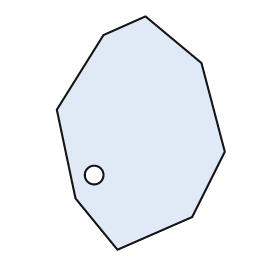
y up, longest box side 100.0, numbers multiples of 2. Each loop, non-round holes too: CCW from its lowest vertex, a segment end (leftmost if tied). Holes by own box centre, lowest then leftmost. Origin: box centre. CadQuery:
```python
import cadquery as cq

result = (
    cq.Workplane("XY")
    .moveTo(-10.0, -50.0)
    .lineTo(22.0, -36.0)
    .lineTo(36.0, -8.0)
    .lineTo(26.0, 30.0)
    .lineTo(2.0, 50.0)
    .lineTo(-16.0, 42.0)
    .lineTo(-36.0, 10.0)
    .lineTo(-28.0, -28.0)
    .close()
    .moveTo(-20.0, -18.0)
    .circle(4.0)
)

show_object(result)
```